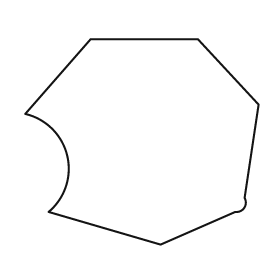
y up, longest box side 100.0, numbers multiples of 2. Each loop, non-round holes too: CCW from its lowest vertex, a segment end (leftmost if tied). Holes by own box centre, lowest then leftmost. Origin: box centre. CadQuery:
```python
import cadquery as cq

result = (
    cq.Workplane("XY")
    .moveTo(8.0, -44.0)
    .lineTo(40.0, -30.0)
    .threePointArc((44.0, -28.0), (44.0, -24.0))
    .lineTo(50.0, 16.0)
    .lineTo(24.0, 44.0)
    .lineTo(-22.0, 44.0)
    .lineTo(-50.0, 12.0)
    .threePointArc((-32.0, -6.0), (-40.0, -30.0))
    .close()
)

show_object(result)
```